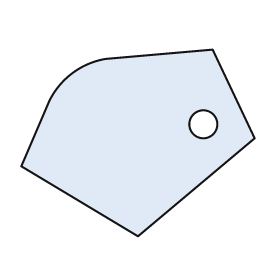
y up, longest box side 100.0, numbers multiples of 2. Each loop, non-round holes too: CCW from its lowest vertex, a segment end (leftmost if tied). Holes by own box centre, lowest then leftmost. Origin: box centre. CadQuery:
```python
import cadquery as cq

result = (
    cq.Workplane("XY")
    .moveTo(0.0, -40.0)
    .lineTo(50.0, 2.0)
    .lineTo(32.0, 40.0)
    .lineTo(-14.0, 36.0)
    .threePointArc((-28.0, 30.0), (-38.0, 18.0))
    .lineTo(-50.0, -10.0)
    .close()
    .moveTo(28.0, 8.0)
    .circle(6.0)
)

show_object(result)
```